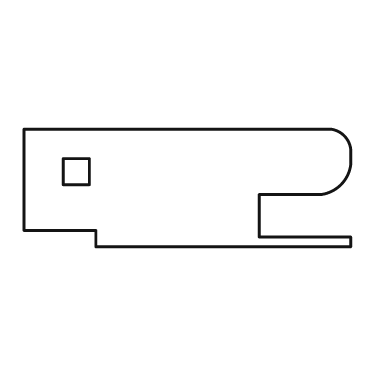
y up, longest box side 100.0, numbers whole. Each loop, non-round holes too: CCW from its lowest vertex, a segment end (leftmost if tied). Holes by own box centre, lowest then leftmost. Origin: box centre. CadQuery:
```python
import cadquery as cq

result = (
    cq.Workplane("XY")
    .moveTo(-28.0, -18.0)
    .lineTo(50.0, -18.0)
    .lineTo(50.0, -15.0)
    .lineTo(22.0, -15.0)
    .lineTo(22.0, -2.0)
    .lineTo(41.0, -2.0)
    .threePointArc((47.0, 1.0), (50.0, 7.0))
    .lineTo(50.0, 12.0)
    .threePointArc((48.0, 16.0), (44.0, 18.0))
    .lineTo(-50.0, 18.0)
    .lineTo(-50.0, -13.0)
    .lineTo(-28.0, -13.0)
    .close()
    .moveTo(-38.0, 1.0)
    .lineTo(-30.0, 1.0)
    .lineTo(-30.0, 9.0)
    .lineTo(-38.0, 9.0)
    .close()
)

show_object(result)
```